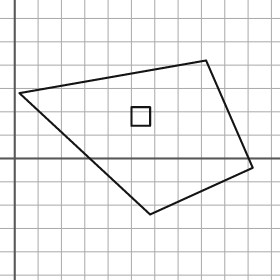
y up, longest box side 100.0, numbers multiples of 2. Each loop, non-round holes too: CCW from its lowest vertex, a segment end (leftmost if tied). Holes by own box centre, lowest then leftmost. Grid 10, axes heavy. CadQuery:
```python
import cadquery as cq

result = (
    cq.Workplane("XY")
    .moveTo(58.0, -24.0)
    .lineTo(102.0, -4.0)
    .lineTo(82.0, 42.0)
    .lineTo(2.0, 28.0)
    .close()
    .moveTo(50.0, 14.0)
    .lineTo(58.0, 14.0)
    .lineTo(58.0, 22.0)
    .lineTo(50.0, 22.0)
    .close()
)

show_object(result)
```